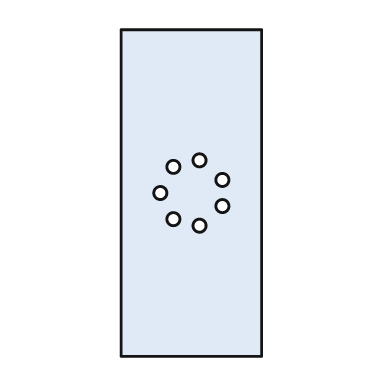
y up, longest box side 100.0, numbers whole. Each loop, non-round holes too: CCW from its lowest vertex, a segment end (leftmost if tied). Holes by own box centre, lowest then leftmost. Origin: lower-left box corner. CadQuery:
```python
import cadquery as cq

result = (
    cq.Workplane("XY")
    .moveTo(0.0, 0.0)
    .lineTo(43.0, 0.0)
    .lineTo(43.0, 100.0)
    .lineTo(0.0, 100.0)
    .close()
    .moveTo(24.0, 40.0)
    .circle(2.0)
    .moveTo(16.0, 42.0)
    .circle(2.0)
    .moveTo(31.0, 46.0)
    .circle(2.0)
    .moveTo(12.0, 50.0)
    .circle(2.0)
    .moveTo(31.0, 54.0)
    .circle(2.0)
    .moveTo(16.0, 58.0)
    .circle(2.0)
    .moveTo(24.0, 60.0)
    .circle(2.0)
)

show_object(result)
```